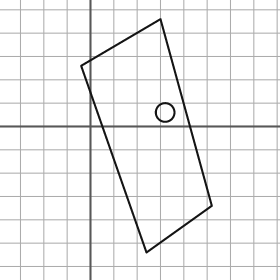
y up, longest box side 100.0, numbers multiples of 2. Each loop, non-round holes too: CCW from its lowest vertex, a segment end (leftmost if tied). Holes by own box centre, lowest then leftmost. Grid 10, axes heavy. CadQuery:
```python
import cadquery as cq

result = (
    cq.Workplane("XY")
    .moveTo(24.0, -54.0)
    .lineTo(52.0, -34.0)
    .lineTo(30.0, 46.0)
    .lineTo(-4.0, 26.0)
    .close()
    .moveTo(32.0, 6.0)
    .circle(4.0)
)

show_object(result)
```